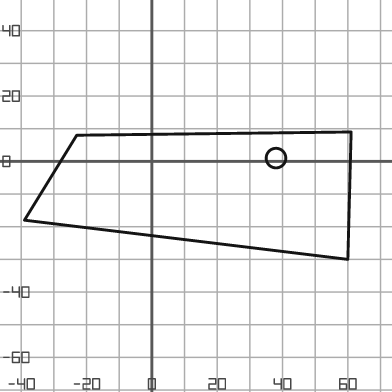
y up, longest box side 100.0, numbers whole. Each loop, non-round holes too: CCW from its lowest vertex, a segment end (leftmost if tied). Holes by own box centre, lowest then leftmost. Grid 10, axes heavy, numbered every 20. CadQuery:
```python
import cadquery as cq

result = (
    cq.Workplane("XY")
    .moveTo(60.0, -30.0)
    .lineTo(61.0, 9.0)
    .lineTo(-23.0, 8.0)
    .lineTo(-39.0, -18.0)
    .close()
    .moveTo(38.0, 1.0)
    .circle(3.0)
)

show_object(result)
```